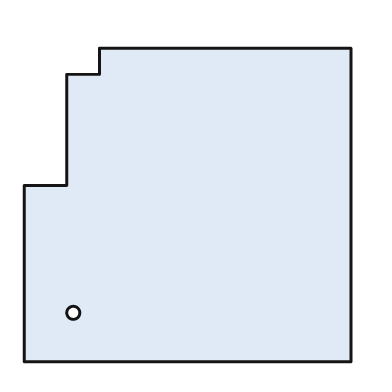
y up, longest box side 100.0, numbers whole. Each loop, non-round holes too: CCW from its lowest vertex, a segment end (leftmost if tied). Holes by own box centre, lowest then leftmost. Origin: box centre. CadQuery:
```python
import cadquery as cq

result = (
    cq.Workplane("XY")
    .moveTo(-50.0, -48.0)
    .lineTo(50.0, -48.0)
    .lineTo(50.0, 48.0)
    .lineTo(-27.0, 48.0)
    .lineTo(-27.0, 40.0)
    .lineTo(-37.0, 40.0)
    .lineTo(-37.0, 6.0)
    .lineTo(-50.0, 6.0)
    .close()
    .moveTo(-35.0, -33.0)
    .circle(2.0)
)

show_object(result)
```